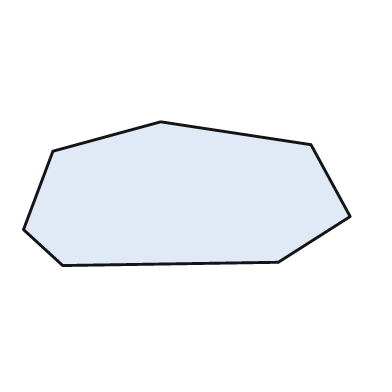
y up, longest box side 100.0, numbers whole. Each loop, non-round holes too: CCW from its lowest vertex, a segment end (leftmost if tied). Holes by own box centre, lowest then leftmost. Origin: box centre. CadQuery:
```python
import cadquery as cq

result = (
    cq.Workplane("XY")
    .moveTo(-38.0, -22.0)
    .lineTo(28.0, -21.0)
    .lineTo(50.0, -7.0)
    .lineTo(38.0, 15.0)
    .lineTo(-8.0, 22.0)
    .lineTo(-41.0, 13.0)
    .lineTo(-50.0, -11.0)
    .close()
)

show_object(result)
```